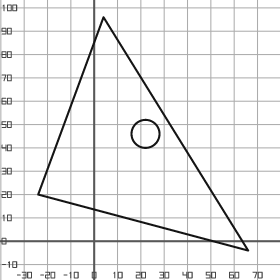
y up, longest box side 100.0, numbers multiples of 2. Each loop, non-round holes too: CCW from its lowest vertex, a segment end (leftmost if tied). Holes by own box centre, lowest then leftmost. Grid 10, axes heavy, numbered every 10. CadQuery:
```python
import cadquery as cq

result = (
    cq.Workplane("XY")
    .moveTo(66.0, -4.0)
    .lineTo(4.0, 96.0)
    .lineTo(-24.0, 20.0)
    .close()
    .moveTo(22.0, 46.0)
    .circle(6.0)
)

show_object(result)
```